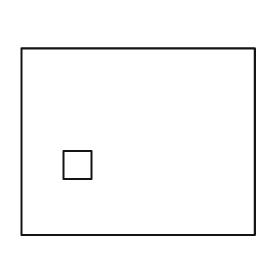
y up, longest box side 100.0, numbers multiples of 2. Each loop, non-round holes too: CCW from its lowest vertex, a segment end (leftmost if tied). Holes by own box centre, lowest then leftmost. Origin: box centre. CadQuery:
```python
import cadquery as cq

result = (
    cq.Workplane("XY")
    .moveTo(-50.0, -40.0)
    .lineTo(50.0, -40.0)
    .lineTo(50.0, 40.0)
    .lineTo(-50.0, 40.0)
    .close()
    .moveTo(-32.0, -16.0)
    .lineTo(-20.0, -16.0)
    .lineTo(-20.0, -4.0)
    .lineTo(-32.0, -4.0)
    .close()
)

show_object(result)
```